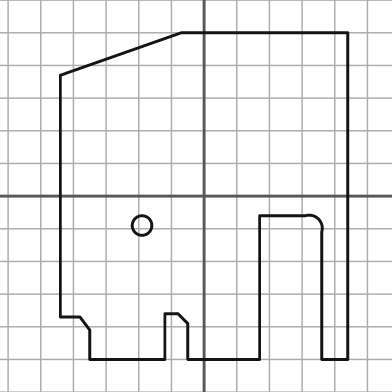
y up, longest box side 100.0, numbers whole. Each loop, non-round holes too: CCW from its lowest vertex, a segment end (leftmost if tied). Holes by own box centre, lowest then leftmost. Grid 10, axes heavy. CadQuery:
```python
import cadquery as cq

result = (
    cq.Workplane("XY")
    .moveTo(-35.0, -50.0)
    .lineTo(-12.0, -50.0)
    .lineTo(-12.0, -36.0)
    .lineTo(-8.0, -36.0)
    .lineTo(-5.0, -39.0)
    .lineTo(-5.0, -50.0)
    .lineTo(17.0, -50.0)
    .lineTo(17.0, -6.0)
    .lineTo(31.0, -6.0)
    .threePointArc((35.0, -7.0), (36.0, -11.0))
    .lineTo(36.0, -50.0)
    .lineTo(44.0, -50.0)
    .lineTo(44.0, 50.0)
    .lineTo(-7.0, 50.0)
    .lineTo(-44.0, 37.0)
    .lineTo(-44.0, -37.0)
    .lineTo(-38.0, -37.0)
    .lineTo(-35.0, -41.0)
    .close()
    .moveTo(-19.0, -9.0)
    .circle(3.0)
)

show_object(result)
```